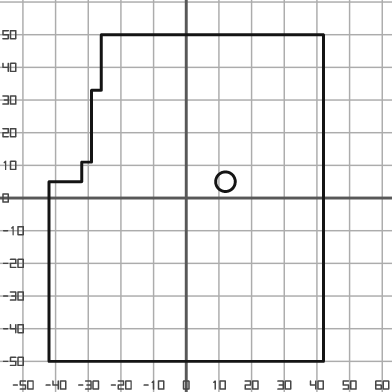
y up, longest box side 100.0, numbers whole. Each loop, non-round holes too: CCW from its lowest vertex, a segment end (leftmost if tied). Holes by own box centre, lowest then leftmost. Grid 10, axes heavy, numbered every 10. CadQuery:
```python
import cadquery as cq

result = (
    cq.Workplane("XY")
    .moveTo(-42.0, -50.0)
    .lineTo(42.0, -50.0)
    .lineTo(42.0, 50.0)
    .lineTo(-26.0, 50.0)
    .lineTo(-26.0, 33.0)
    .lineTo(-29.0, 33.0)
    .lineTo(-29.0, 11.0)
    .lineTo(-32.0, 11.0)
    .lineTo(-32.0, 5.0)
    .lineTo(-42.0, 5.0)
    .close()
    .moveTo(12.0, 5.0)
    .circle(3.0)
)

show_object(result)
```